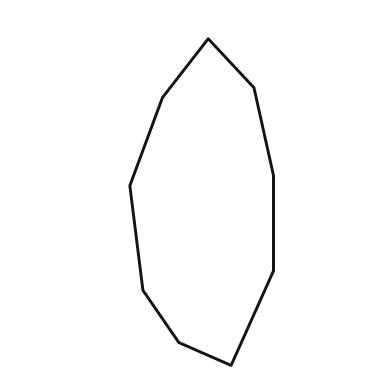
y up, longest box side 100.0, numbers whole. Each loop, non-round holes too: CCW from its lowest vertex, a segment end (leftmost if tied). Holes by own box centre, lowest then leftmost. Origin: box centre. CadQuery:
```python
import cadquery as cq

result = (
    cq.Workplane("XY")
    .moveTo(9.0, -50.0)
    .lineTo(22.0, -21.0)
    .lineTo(22.0, 8.0)
    .lineTo(16.0, 35.0)
    .lineTo(2.0, 50.0)
    .lineTo(-12.0, 32.0)
    .lineTo(-22.0, 5.0)
    .lineTo(-18.0, -27.0)
    .lineTo(-7.0, -43.0)
    .close()
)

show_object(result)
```